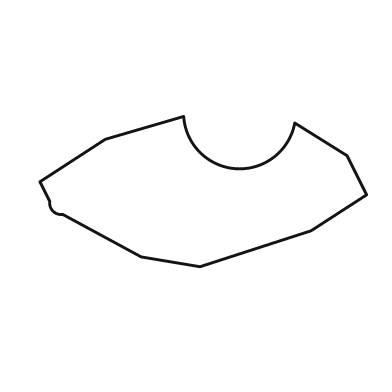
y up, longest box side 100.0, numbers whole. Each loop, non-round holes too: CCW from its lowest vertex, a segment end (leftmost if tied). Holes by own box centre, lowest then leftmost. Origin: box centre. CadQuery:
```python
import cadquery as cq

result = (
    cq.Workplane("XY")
    .moveTo(-1.0, -23.0)
    .lineTo(33.0, -12.0)
    .lineTo(50.0, -1.0)
    .lineTo(44.0, 11.0)
    .lineTo(28.0, 21.0)
    .threePointArc((10.0, 7.0), (-6.0, 23.0))
    .lineTo(-30.0, 16.0)
    .lineTo(-50.0, 3.0)
    .lineTo(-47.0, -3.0)
    .threePointArc((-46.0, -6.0), (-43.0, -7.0))
    .lineTo(-19.0, -20.0)
    .close()
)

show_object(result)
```